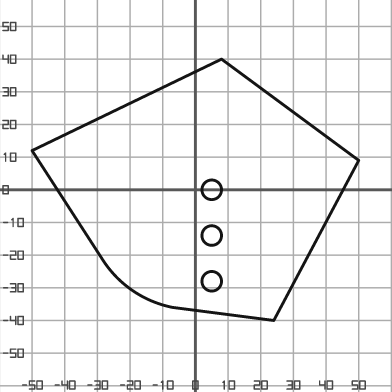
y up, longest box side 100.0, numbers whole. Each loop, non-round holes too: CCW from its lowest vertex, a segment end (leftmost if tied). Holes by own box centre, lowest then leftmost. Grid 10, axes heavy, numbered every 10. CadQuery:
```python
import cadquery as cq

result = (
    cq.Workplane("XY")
    .moveTo(24.0, -40.0)
    .lineTo(50.0, 9.0)
    .lineTo(8.0, 40.0)
    .lineTo(-50.0, 12.0)
    .lineTo(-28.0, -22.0)
    .threePointArc((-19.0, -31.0), (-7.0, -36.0))
    .close()
    .moveTo(5.0, -28.0)
    .circle(3.0)
    .moveTo(5.0, -14.0)
    .circle(3.0)
    .moveTo(5.0, 0.0)
    .circle(3.0)
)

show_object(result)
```